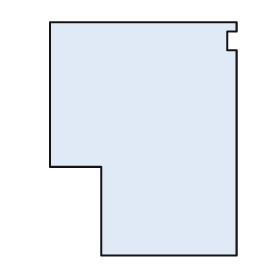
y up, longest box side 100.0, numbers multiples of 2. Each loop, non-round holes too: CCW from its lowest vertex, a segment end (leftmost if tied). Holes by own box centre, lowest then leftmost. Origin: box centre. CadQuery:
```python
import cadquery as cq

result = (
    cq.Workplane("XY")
    .moveTo(-18.0, -50.0)
    .lineTo(40.0, -50.0)
    .lineTo(40.0, 38.0)
    .lineTo(36.0, 38.0)
    .lineTo(36.0, 46.0)
    .lineTo(40.0, 46.0)
    .lineTo(40.0, 50.0)
    .lineTo(-40.0, 50.0)
    .lineTo(-40.0, -12.0)
    .lineTo(-18.0, -12.0)
    .close()
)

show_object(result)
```